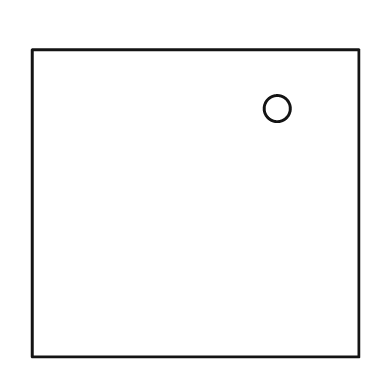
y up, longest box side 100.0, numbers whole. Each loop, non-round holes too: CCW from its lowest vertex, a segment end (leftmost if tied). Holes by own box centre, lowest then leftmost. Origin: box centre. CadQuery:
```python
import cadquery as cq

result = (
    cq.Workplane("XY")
    .moveTo(-50.0, -47.0)
    .lineTo(50.0, -47.0)
    .lineTo(50.0, 47.0)
    .lineTo(-50.0, 47.0)
    .close()
    .moveTo(25.0, 29.0)
    .circle(4.0)
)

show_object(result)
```